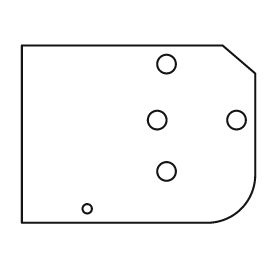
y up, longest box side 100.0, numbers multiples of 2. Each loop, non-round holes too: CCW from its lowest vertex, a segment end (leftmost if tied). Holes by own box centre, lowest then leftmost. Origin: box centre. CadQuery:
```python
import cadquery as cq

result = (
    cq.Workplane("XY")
    .moveTo(-50.0, -38.0)
    .lineTo(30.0, -38.0)
    .threePointArc((44.0, -32.0), (50.0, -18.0))
    .lineTo(50.0, 26.0)
    .lineTo(36.0, 38.0)
    .lineTo(-50.0, 38.0)
    .close()
    .moveTo(-22.0, -32.0)
    .circle(2.0)
    .moveTo(12.0, -16.0)
    .circle(4.0)
    .moveTo(8.0, 6.0)
    .circle(4.0)
    .moveTo(42.0, 6.0)
    .circle(4.0)
    .moveTo(12.0, 30.0)
    .circle(4.0)
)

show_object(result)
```